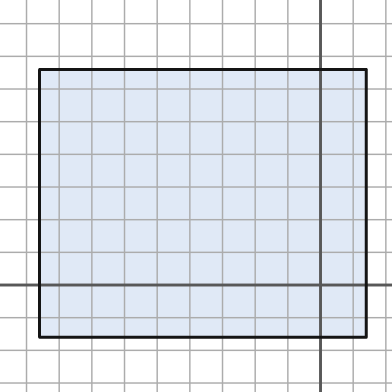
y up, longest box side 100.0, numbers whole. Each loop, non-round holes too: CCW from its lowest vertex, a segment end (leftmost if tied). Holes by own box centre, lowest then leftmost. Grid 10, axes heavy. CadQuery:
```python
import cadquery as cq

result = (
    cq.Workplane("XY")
    .moveTo(-86.0, -16.0)
    .lineTo(14.0, -16.0)
    .lineTo(14.0, 66.0)
    .lineTo(-86.0, 66.0)
    .close()
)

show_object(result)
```